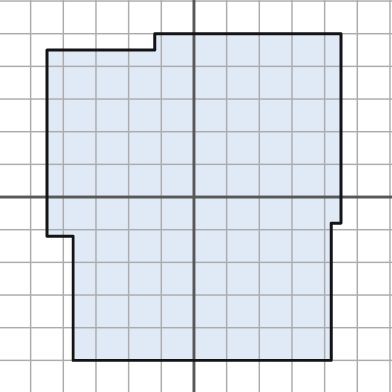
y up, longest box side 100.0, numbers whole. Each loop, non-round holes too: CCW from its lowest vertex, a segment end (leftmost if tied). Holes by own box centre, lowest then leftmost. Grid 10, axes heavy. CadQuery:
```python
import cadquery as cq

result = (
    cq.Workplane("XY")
    .moveTo(-37.0, -50.0)
    .lineTo(42.0, -50.0)
    .lineTo(42.0, -8.0)
    .lineTo(45.0, -8.0)
    .lineTo(45.0, 50.0)
    .lineTo(-12.0, 50.0)
    .lineTo(-12.0, 45.0)
    .lineTo(-45.0, 45.0)
    .lineTo(-45.0, -12.0)
    .lineTo(-37.0, -12.0)
    .close()
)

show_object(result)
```